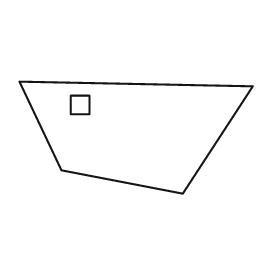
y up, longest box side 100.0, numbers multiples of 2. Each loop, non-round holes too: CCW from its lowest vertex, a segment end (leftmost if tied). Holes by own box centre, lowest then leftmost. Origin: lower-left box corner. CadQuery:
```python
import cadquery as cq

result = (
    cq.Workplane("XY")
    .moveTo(70.0, 0.0)
    .lineTo(100.0, 46.0)
    .lineTo(0.0, 48.0)
    .lineTo(18.0, 10.0)
    .close()
    .moveTo(22.0, 34.0)
    .lineTo(30.0, 34.0)
    .lineTo(30.0, 42.0)
    .lineTo(22.0, 42.0)
    .close()
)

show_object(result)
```